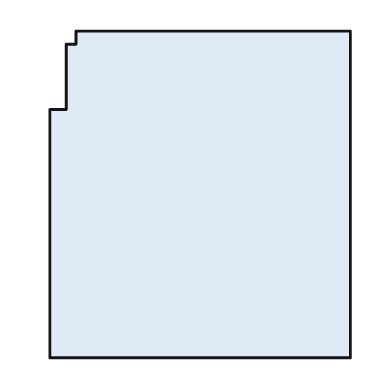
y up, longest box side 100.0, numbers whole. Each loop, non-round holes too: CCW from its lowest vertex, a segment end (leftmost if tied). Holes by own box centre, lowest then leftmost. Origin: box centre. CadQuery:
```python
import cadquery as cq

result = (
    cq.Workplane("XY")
    .moveTo(-46.0, -50.0)
    .lineTo(46.0, -50.0)
    .lineTo(46.0, 50.0)
    .lineTo(-38.0, 50.0)
    .lineTo(-38.0, 46.0)
    .lineTo(-41.0, 46.0)
    .lineTo(-41.0, 26.0)
    .lineTo(-46.0, 26.0)
    .close()
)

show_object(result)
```